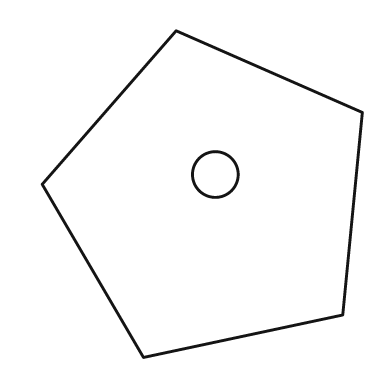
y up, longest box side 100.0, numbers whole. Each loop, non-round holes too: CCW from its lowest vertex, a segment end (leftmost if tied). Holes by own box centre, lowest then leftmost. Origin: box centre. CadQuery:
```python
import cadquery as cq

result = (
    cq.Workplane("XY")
    .moveTo(-18.0, -50.0)
    .lineTo(43.0, -37.0)
    .lineTo(49.0, 25.0)
    .lineTo(-8.0, 50.0)
    .lineTo(-49.0, 3.0)
    .close()
    .moveTo(4.0, 6.0)
    .circle(7.0)
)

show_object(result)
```